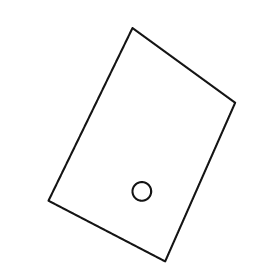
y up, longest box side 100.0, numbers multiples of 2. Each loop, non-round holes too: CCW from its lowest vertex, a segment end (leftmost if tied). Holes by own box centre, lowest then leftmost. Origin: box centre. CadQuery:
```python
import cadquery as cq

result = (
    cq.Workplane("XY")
    .moveTo(10.0, -50.0)
    .lineTo(40.0, 18.0)
    .lineTo(-4.0, 50.0)
    .lineTo(-40.0, -24.0)
    .close()
    .moveTo(0.0, -20.0)
    .circle(4.0)
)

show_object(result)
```